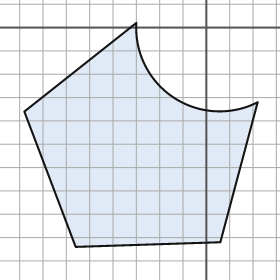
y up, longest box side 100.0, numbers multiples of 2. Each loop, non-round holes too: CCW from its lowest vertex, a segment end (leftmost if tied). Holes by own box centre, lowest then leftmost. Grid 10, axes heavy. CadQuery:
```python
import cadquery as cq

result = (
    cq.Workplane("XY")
    .moveTo(-56.0, -94.0)
    .lineTo(6.0, -92.0)
    .lineTo(22.0, -32.0)
    .threePointArc((-14.0, -30.0), (-30.0, 2.0))
    .lineTo(-78.0, -36.0)
    .close()
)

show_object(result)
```